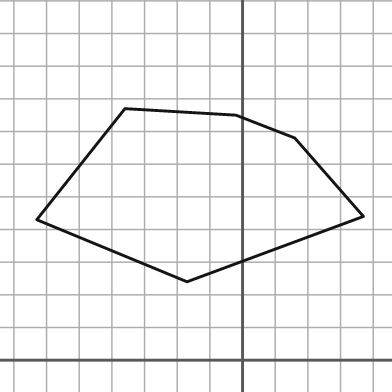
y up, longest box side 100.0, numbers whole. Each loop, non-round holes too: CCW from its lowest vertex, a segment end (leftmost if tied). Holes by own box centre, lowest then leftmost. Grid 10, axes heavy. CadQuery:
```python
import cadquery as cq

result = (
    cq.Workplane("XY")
    .moveTo(-17.0, 24.0)
    .lineTo(37.0, 44.0)
    .lineTo(16.0, 68.0)
    .lineTo(-2.0, 75.0)
    .lineTo(-36.0, 77.0)
    .lineTo(-63.0, 43.0)
    .close()
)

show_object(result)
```